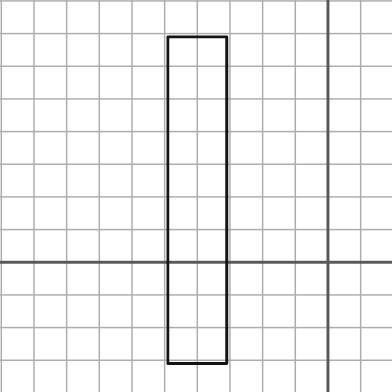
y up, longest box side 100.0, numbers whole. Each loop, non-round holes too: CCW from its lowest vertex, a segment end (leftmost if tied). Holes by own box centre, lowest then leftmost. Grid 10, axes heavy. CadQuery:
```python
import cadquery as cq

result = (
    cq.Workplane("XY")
    .moveTo(-49.0, -31.0)
    .lineTo(-31.0, -31.0)
    .lineTo(-31.0, 69.0)
    .lineTo(-49.0, 69.0)
    .close()
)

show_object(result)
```